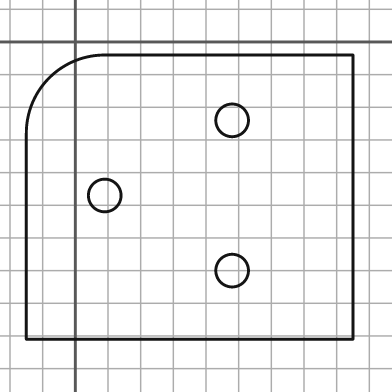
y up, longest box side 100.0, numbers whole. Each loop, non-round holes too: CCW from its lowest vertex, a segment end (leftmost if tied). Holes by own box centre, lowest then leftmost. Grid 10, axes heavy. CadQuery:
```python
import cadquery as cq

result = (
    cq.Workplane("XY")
    .moveTo(-15.0, -91.0)
    .lineTo(85.0, -91.0)
    .lineTo(85.0, -4.0)
    .lineTo(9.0, -4.0)
    .threePointArc((-8.0, -11.0), (-15.0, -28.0))
    .close()
    .moveTo(48.0, -70.0)
    .circle(5.0)
    .moveTo(9.0, -47.0)
    .circle(5.0)
    .moveTo(48.0, -24.0)
    .circle(5.0)
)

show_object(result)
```